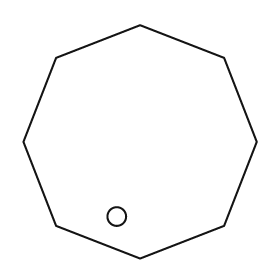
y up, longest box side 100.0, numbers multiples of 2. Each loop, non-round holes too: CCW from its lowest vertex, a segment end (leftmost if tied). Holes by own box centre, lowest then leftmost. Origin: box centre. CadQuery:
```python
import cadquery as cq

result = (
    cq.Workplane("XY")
    .moveTo(0.0, -50.0)
    .lineTo(36.0, -36.0)
    .lineTo(50.0, 0.0)
    .lineTo(36.0, 36.0)
    .lineTo(0.0, 50.0)
    .lineTo(-36.0, 36.0)
    .lineTo(-50.0, 0.0)
    .lineTo(-36.0, -36.0)
    .close()
    .moveTo(-10.0, -32.0)
    .circle(4.0)
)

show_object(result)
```